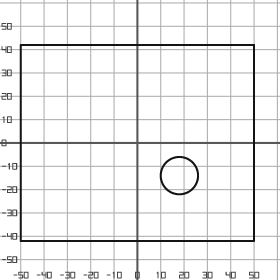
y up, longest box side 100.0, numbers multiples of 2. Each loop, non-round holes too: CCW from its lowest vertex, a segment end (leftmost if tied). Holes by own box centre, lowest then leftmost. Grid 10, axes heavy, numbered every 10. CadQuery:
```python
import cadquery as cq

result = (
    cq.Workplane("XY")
    .moveTo(-50.0, -42.0)
    .lineTo(50.0, -42.0)
    .lineTo(50.0, 42.0)
    .lineTo(-50.0, 42.0)
    .close()
    .moveTo(18.0, -14.0)
    .circle(8.0)
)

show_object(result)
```